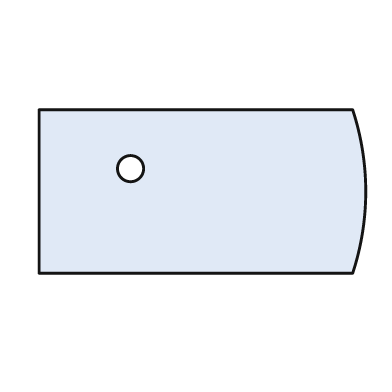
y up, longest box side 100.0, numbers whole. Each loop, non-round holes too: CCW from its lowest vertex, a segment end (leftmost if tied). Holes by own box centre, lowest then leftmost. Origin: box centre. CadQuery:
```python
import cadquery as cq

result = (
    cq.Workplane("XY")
    .moveTo(-50.0, -25.0)
    .lineTo(46.0, -25.0)
    .threePointArc((50.0, 0.0), (46.0, 25.0))
    .lineTo(-50.0, 25.0)
    .close()
    .moveTo(-22.0, 7.0)
    .circle(4.0)
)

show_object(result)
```